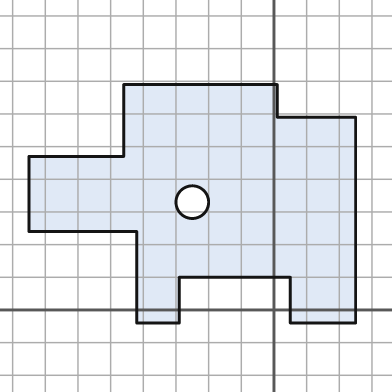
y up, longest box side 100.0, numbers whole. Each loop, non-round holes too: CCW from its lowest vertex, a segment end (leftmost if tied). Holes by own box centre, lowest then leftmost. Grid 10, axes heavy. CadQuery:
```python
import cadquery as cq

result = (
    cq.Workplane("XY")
    .moveTo(-42.0, -4.0)
    .lineTo(-29.0, -4.0)
    .lineTo(-29.0, 10.0)
    .lineTo(5.0, 10.0)
    .lineTo(5.0, -4.0)
    .lineTo(25.0, -4.0)
    .lineTo(25.0, 59.0)
    .lineTo(1.0, 59.0)
    .lineTo(1.0, 69.0)
    .lineTo(-46.0, 69.0)
    .lineTo(-46.0, 47.0)
    .lineTo(-75.0, 47.0)
    .lineTo(-75.0, 24.0)
    .lineTo(-42.0, 24.0)
    .close()
    .moveTo(-25.0, 33.0)
    .circle(5.0)
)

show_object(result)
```